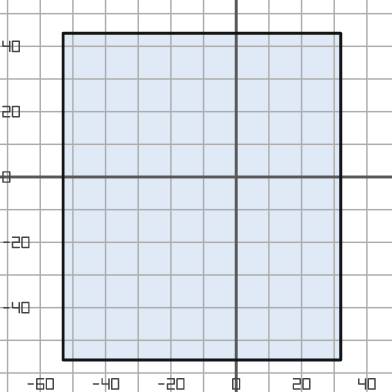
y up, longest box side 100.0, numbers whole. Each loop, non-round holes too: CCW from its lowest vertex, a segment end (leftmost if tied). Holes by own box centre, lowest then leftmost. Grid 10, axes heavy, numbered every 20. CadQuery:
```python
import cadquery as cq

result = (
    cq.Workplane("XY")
    .moveTo(-53.0, -56.0)
    .lineTo(32.0, -56.0)
    .lineTo(32.0, 44.0)
    .lineTo(-53.0, 44.0)
    .close()
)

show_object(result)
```